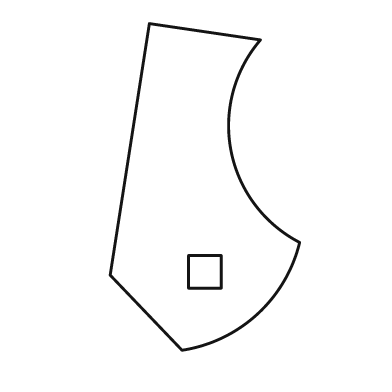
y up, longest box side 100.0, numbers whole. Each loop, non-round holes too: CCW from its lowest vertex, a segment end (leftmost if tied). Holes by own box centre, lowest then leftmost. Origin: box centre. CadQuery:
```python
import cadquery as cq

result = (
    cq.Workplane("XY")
    .moveTo(-7.0, -50.0)
    .threePointArc((16.0, -39.0), (29.0, -17.0))
    .threePointArc((8.0, 11.0), (17.0, 45.0))
    .lineTo(-17.0, 50.0)
    .lineTo(-29.0, -27.0)
    .close()
    .moveTo(-5.0, -31.0)
    .lineTo(5.0, -31.0)
    .lineTo(5.0, -21.0)
    .lineTo(-5.0, -21.0)
    .close()
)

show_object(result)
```